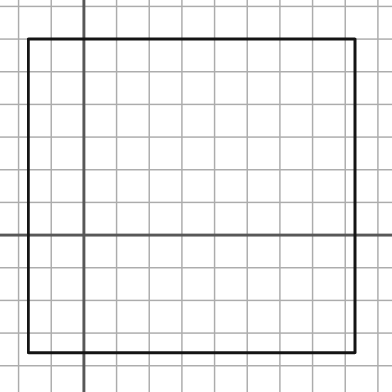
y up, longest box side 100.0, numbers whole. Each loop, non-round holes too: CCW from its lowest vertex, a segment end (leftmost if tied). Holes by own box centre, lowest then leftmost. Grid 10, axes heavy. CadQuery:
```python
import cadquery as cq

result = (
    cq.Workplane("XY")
    .moveTo(-17.0, -36.0)
    .lineTo(83.0, -36.0)
    .lineTo(83.0, 60.0)
    .lineTo(-17.0, 60.0)
    .close()
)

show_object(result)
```